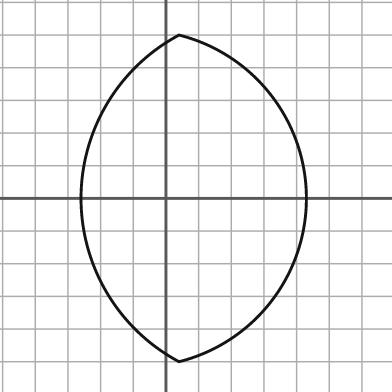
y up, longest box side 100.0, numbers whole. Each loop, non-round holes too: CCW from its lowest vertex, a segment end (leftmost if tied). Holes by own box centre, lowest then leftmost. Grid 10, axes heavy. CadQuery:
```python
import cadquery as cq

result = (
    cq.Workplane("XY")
    .moveTo(4.0, -50.0)
    .threePointArc((43.0, 0.0), (4.0, 50.0))
    .threePointArc((-26.0, 0.0), (4.0, -50.0))
    .close()
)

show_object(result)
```